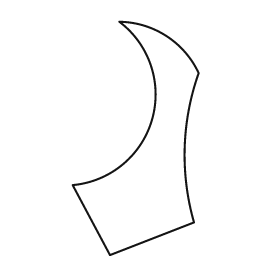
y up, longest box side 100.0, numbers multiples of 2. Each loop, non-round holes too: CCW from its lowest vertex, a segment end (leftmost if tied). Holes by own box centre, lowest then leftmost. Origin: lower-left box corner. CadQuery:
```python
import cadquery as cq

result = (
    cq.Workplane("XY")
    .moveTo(16.0, 0.0)
    .lineTo(52.0, 14.0)
    .threePointArc((48.0, 46.0), (54.0, 78.0))
    .threePointArc((40.0, 94.0), (20.0, 100.0))
    .threePointArc((34.0, 58.0), (0.0, 30.0))
    .close()
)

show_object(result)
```